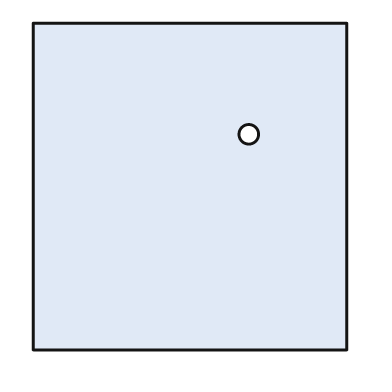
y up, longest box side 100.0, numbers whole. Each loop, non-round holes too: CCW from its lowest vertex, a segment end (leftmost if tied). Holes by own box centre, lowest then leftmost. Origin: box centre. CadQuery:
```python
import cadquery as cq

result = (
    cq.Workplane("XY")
    .moveTo(-48.0, -50.0)
    .lineTo(48.0, -50.0)
    .lineTo(48.0, 50.0)
    .lineTo(-48.0, 50.0)
    .close()
    .moveTo(18.0, 16.0)
    .circle(3.0)
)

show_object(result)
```